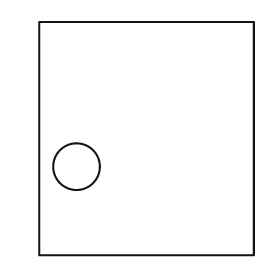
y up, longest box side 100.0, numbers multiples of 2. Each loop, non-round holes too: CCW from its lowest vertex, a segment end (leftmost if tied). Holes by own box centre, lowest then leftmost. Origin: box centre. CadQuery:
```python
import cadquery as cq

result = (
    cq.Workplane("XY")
    .moveTo(-46.0, -50.0)
    .lineTo(46.0, -50.0)
    .lineTo(46.0, 50.0)
    .lineTo(-46.0, 50.0)
    .close()
    .moveTo(-30.0, -12.0)
    .circle(10.0)
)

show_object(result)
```